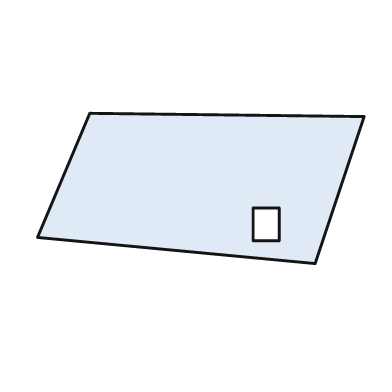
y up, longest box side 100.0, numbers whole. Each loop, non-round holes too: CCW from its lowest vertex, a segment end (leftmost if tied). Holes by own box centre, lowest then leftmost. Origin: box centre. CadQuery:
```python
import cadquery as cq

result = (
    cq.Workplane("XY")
    .moveTo(35.0, -23.0)
    .lineTo(50.0, 22.0)
    .lineTo(-34.0, 23.0)
    .lineTo(-50.0, -15.0)
    .close()
    .moveTo(16.0, -16.0)
    .lineTo(24.0, -16.0)
    .lineTo(24.0, -6.0)
    .lineTo(16.0, -6.0)
    .close()
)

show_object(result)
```